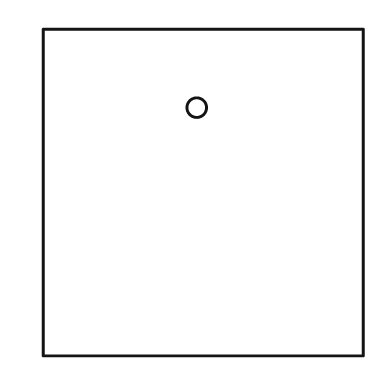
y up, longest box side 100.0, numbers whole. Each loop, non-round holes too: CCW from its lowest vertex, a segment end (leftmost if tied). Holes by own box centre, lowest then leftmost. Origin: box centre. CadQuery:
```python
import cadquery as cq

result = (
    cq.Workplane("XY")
    .moveTo(-49.0, -50.0)
    .lineTo(49.0, -50.0)
    .lineTo(49.0, 50.0)
    .lineTo(-49.0, 50.0)
    .close()
    .moveTo(-2.0, 26.0)
    .circle(3.0)
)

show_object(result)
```